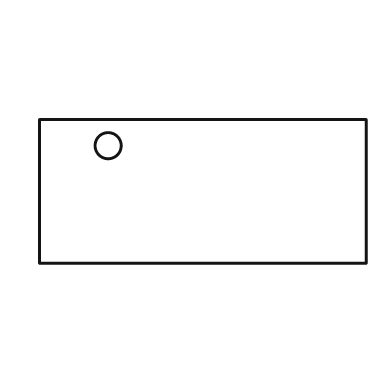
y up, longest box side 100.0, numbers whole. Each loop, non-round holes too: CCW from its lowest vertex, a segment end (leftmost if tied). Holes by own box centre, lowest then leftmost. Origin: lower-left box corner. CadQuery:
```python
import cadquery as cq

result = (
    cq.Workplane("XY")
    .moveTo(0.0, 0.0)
    .lineTo(100.0, 0.0)
    .lineTo(100.0, 44.0)
    .lineTo(0.0, 44.0)
    .close()
    .moveTo(21.0, 36.0)
    .circle(4.0)
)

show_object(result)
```